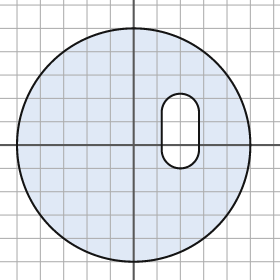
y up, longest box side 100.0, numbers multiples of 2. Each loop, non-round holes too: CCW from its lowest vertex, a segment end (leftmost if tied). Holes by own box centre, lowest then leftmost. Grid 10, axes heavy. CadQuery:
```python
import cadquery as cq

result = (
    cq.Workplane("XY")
    .moveTo(0.0, 0.0)
    .circle(50.0)
    .moveTo(12.0, -2.0)
    .threePointArc((20.0, -10.0), (28.0, -2.0))
    .lineTo(28.0, 14.0)
    .threePointArc((20.0, 22.0), (12.0, 14.0))
    .close()
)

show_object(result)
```